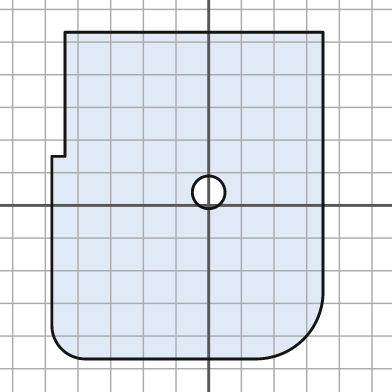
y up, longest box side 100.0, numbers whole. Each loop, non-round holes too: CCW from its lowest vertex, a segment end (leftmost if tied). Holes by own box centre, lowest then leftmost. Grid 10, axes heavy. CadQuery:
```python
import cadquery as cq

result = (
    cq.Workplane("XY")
    .moveTo(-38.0, -47.0)
    .lineTo(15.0, -47.0)
    .threePointArc((29.0, -41.0), (35.0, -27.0))
    .lineTo(35.0, 53.0)
    .lineTo(-44.0, 53.0)
    .lineTo(-44.0, 15.0)
    .lineTo(-48.0, 15.0)
    .lineTo(-48.0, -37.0)
    .threePointArc((-45.0, -44.0), (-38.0, -47.0))
    .close()
    .moveTo(0.0, 4.0)
    .circle(5.0)
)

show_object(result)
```